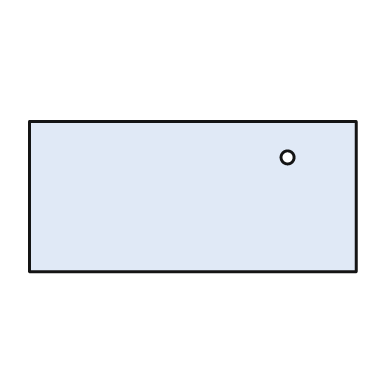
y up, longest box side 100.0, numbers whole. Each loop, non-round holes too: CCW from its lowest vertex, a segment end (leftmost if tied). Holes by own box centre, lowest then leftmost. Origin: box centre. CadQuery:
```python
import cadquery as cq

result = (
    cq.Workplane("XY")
    .moveTo(-50.0, -23.0)
    .lineTo(50.0, -23.0)
    .lineTo(50.0, 23.0)
    .lineTo(-50.0, 23.0)
    .close()
    .moveTo(29.0, 12.0)
    .circle(2.0)
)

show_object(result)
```